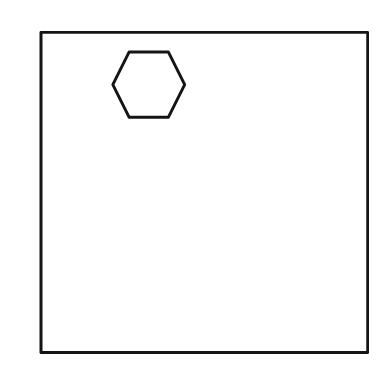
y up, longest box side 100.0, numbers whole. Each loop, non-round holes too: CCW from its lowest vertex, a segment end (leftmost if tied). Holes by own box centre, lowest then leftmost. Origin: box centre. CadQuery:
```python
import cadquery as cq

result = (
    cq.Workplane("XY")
    .moveTo(-50.0, -49.0)
    .lineTo(50.0, -49.0)
    .lineTo(50.0, 49.0)
    .lineTo(-50.0, 49.0)
    .close()
    .moveTo(-23.0, 23.0)
    .lineTo(-11.0, 23.0)
    .lineTo(-6.0, 33.0)
    .lineTo(-11.0, 43.0)
    .lineTo(-23.0, 43.0)
    .lineTo(-28.0, 33.0)
    .close()
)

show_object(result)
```